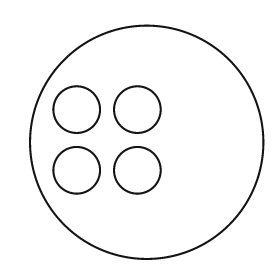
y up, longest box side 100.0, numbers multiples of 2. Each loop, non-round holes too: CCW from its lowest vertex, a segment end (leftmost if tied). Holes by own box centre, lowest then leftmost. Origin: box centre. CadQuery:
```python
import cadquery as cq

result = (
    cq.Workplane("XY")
    .moveTo(0.0, 0.0)
    .circle(50.0)
    .moveTo(-30.0, -12.0)
    .circle(10.0)
    .moveTo(-4.0, -12.0)
    .circle(10.0)
    .moveTo(-30.0, 14.0)
    .circle(10.0)
    .moveTo(-4.0, 14.0)
    .circle(10.0)
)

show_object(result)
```